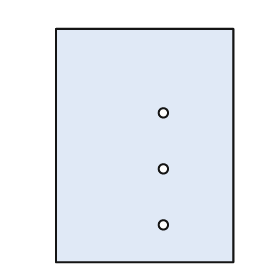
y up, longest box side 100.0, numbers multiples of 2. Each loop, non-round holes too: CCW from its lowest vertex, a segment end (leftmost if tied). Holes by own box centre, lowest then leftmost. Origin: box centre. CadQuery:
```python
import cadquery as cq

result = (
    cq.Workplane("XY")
    .moveTo(-38.0, -50.0)
    .lineTo(38.0, -50.0)
    .lineTo(38.0, 50.0)
    .lineTo(-38.0, 50.0)
    .close()
    .moveTo(8.0, -34.0)
    .circle(2.0)
    .moveTo(8.0, -10.0)
    .circle(2.0)
    .moveTo(8.0, 14.0)
    .circle(2.0)
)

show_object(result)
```